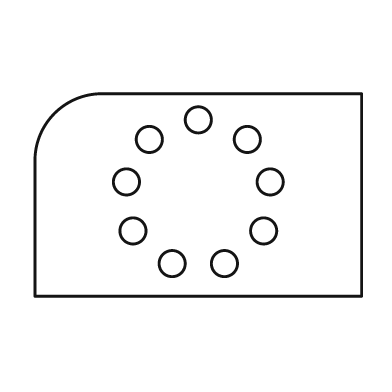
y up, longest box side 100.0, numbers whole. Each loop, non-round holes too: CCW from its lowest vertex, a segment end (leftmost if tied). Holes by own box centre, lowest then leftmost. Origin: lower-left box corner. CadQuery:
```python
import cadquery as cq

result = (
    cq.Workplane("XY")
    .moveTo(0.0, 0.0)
    .lineTo(100.0, 0.0)
    .lineTo(100.0, 62.0)
    .lineTo(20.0, 62.0)
    .threePointArc((6.0, 56.0), (0.0, 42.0))
    .close()
    .moveTo(42.0, 10.0)
    .circle(4.0)
    .moveTo(58.0, 10.0)
    .circle(4.0)
    .moveTo(30.0, 20.0)
    .circle(4.0)
    .moveTo(70.0, 20.0)
    .circle(4.0)
    .moveTo(28.0, 35.0)
    .circle(4.0)
    .moveTo(72.0, 35.0)
    .circle(4.0)
    .moveTo(35.0, 48.0)
    .circle(4.0)
    .moveTo(65.0, 48.0)
    .circle(4.0)
    .moveTo(50.0, 54.0)
    .circle(4.0)
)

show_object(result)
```